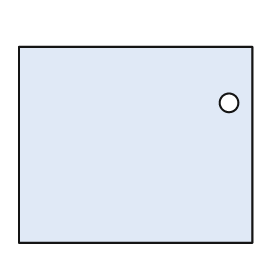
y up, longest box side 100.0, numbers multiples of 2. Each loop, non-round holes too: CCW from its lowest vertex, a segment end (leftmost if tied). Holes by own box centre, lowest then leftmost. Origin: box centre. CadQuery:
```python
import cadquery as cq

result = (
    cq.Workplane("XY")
    .moveTo(-50.0, -42.0)
    .lineTo(50.0, -42.0)
    .lineTo(50.0, 42.0)
    .lineTo(-50.0, 42.0)
    .close()
    .moveTo(40.0, 18.0)
    .circle(4.0)
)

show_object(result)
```